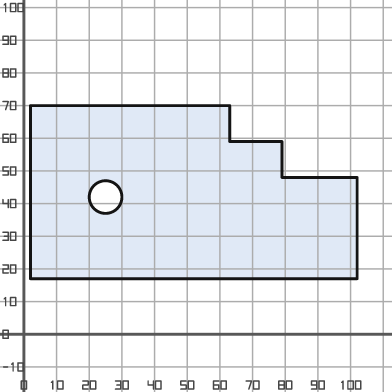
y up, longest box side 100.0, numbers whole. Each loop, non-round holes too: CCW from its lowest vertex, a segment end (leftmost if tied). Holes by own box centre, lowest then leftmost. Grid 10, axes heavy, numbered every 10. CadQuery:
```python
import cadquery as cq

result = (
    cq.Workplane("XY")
    .moveTo(2.0, 17.0)
    .lineTo(102.0, 17.0)
    .lineTo(102.0, 48.0)
    .lineTo(79.0, 48.0)
    .lineTo(79.0, 59.0)
    .lineTo(63.0, 59.0)
    .lineTo(63.0, 70.0)
    .lineTo(2.0, 70.0)
    .close()
    .moveTo(25.0, 42.0)
    .circle(5.0)
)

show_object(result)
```